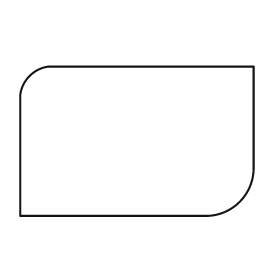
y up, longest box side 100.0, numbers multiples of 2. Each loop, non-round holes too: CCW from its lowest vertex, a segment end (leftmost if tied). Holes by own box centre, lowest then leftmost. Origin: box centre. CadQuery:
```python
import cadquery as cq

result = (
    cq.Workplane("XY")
    .moveTo(-50.0, -32.0)
    .lineTo(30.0, -32.0)
    .threePointArc((44.0, -26.0), (50.0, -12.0))
    .lineTo(50.0, 32.0)
    .lineTo(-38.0, 32.0)
    .threePointArc((-46.0, 28.0), (-50.0, 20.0))
    .close()
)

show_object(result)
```